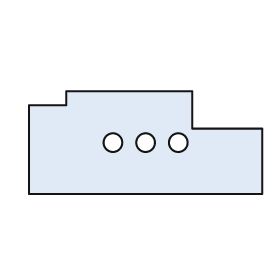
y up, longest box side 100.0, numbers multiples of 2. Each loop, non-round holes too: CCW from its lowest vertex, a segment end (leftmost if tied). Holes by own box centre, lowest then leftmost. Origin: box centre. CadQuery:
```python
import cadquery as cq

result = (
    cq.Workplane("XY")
    .moveTo(-50.0, -22.0)
    .lineTo(50.0, -22.0)
    .lineTo(50.0, 6.0)
    .lineTo(20.0, 6.0)
    .lineTo(20.0, 22.0)
    .lineTo(-34.0, 22.0)
    .lineTo(-34.0, 16.0)
    .lineTo(-50.0, 16.0)
    .close()
    .moveTo(-14.0, 0.0)
    .circle(4.0)
    .moveTo(0.0, 0.0)
    .circle(4.0)
    .moveTo(14.0, 0.0)
    .circle(4.0)
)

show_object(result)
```